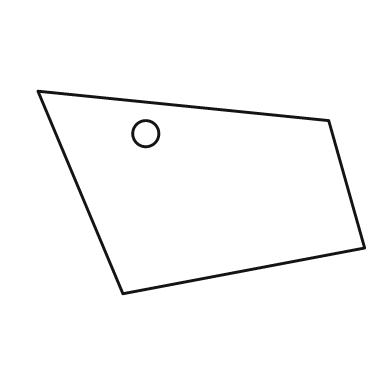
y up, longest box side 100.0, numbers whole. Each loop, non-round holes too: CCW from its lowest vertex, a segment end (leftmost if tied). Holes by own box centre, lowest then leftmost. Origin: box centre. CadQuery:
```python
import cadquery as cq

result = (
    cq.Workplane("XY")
    .moveTo(-24.0, -31.0)
    .lineTo(50.0, -17.0)
    .lineTo(39.0, 22.0)
    .lineTo(-50.0, 31.0)
    .close()
    .moveTo(-17.0, 18.0)
    .circle(4.0)
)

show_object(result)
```